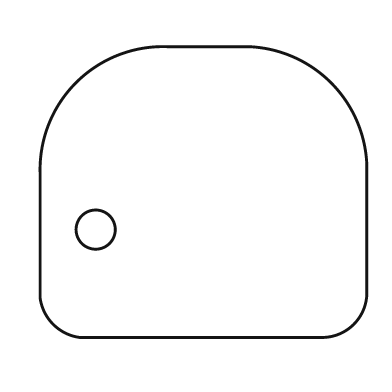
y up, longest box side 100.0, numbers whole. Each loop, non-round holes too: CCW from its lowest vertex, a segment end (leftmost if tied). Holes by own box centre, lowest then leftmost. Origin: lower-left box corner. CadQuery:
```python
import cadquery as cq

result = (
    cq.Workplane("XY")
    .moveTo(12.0, 0.0)
    .lineTo(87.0, 0.0)
    .threePointArc((96.0, 4.0), (100.0, 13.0))
    .lineTo(100.0, 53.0)
    .threePointArc((89.0, 78.0), (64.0, 89.0))
    .lineTo(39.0, 89.0)
    .threePointArc((11.0, 78.0), (0.0, 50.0))
    .lineTo(0.0, 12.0)
    .threePointArc((4.0, 4.0), (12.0, 0.0))
    .close()
    .moveTo(17.0, 33.0)
    .circle(6.0)
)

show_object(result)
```